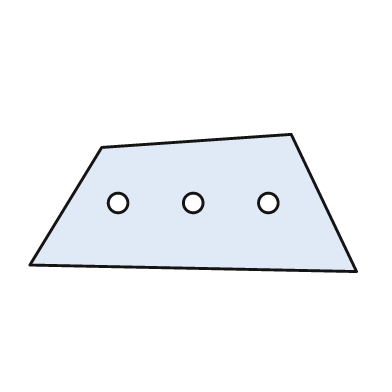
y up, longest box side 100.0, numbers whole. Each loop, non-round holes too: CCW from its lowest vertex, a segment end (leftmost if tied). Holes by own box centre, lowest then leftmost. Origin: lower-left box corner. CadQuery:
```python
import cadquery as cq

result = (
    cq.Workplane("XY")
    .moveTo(100.0, 0.0)
    .lineTo(80.0, 42.0)
    .lineTo(22.0, 38.0)
    .lineTo(0.0, 2.0)
    .close()
    .moveTo(27.0, 21.0)
    .circle(3.0)
    .moveTo(50.0, 21.0)
    .circle(3.0)
    .moveTo(73.0, 21.0)
    .circle(3.0)
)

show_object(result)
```